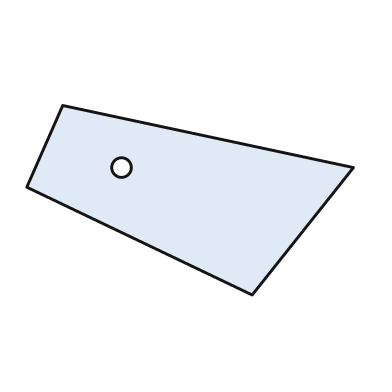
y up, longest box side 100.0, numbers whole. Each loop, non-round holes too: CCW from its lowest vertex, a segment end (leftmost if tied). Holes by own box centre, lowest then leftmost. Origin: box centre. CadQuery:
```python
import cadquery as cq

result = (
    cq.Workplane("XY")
    .moveTo(19.0, -29.0)
    .lineTo(50.0, 10.0)
    .lineTo(-39.0, 29.0)
    .lineTo(-50.0, 4.0)
    .close()
    .moveTo(-21.0, 10.0)
    .circle(3.0)
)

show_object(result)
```